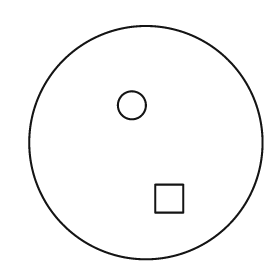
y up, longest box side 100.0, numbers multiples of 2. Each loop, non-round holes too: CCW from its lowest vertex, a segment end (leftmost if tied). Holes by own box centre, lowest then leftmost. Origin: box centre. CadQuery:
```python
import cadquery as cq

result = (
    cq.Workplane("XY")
    .moveTo(0.0, 0.0)
    .circle(50.0)
    .moveTo(4.0, -30.0)
    .lineTo(16.0, -30.0)
    .lineTo(16.0, -18.0)
    .lineTo(4.0, -18.0)
    .close()
    .moveTo(-6.0, 16.0)
    .circle(6.0)
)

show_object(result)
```